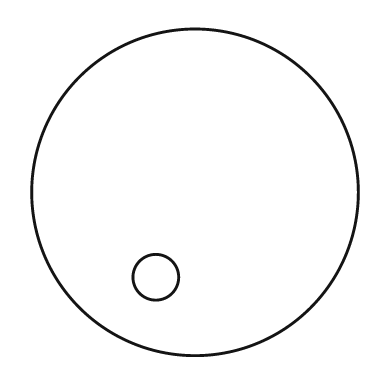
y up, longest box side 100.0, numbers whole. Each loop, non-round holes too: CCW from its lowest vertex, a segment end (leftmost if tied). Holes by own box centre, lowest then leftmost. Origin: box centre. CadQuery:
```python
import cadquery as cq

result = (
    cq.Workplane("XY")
    .moveTo(0.0, 0.0)
    .circle(50.0)
    .moveTo(-12.0, -26.0)
    .circle(7.0)
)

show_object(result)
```